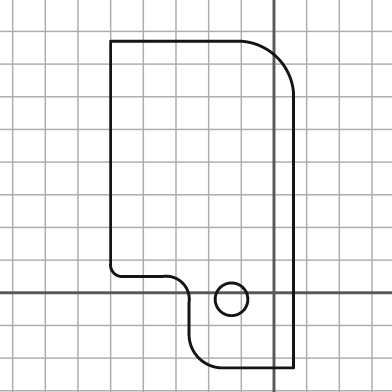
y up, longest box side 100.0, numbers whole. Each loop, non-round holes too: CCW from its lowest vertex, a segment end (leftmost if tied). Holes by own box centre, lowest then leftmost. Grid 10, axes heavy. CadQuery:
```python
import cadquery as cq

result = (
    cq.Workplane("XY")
    .moveTo(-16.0, -23.0)
    .lineTo(6.0, -23.0)
    .lineTo(6.0, 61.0)
    .threePointArc((1.0, 72.0), (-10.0, 77.0))
    .lineTo(-50.0, 77.0)
    .lineTo(-50.0, 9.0)
    .threePointArc((-49.0, 6.0), (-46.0, 5.0))
    .lineTo(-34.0, 5.0)
    .threePointArc((-28.0, 3.0), (-26.0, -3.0))
    .lineTo(-26.0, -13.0)
    .threePointArc((-23.0, -20.0), (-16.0, -23.0))
    .close()
    .moveTo(-13.0, -2.0)
    .circle(5.0)
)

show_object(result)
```